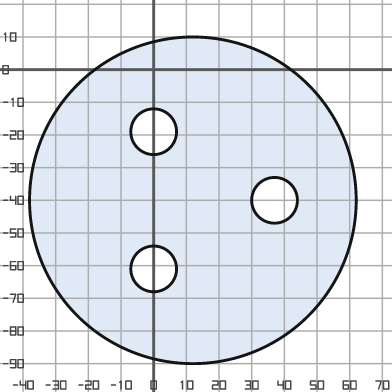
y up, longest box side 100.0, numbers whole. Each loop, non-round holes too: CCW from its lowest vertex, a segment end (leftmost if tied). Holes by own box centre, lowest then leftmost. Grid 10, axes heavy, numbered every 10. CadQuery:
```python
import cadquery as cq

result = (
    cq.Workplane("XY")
    .moveTo(12.0, -40.0)
    .circle(50.0)
    .moveTo(0.0, -61.0)
    .circle(7.0)
    .moveTo(37.0, -40.0)
    .circle(7.0)
    .moveTo(0.0, -19.0)
    .circle(7.0)
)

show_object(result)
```